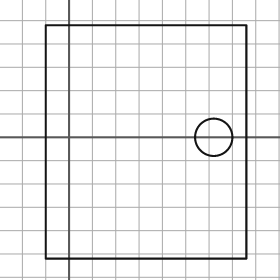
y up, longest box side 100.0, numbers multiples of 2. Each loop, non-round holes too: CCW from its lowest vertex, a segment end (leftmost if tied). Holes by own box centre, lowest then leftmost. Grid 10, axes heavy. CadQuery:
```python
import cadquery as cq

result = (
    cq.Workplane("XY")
    .moveTo(-10.0, -52.0)
    .lineTo(76.0, -52.0)
    .lineTo(76.0, 48.0)
    .lineTo(-10.0, 48.0)
    .close()
    .moveTo(62.0, 0.0)
    .circle(8.0)
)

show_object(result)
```